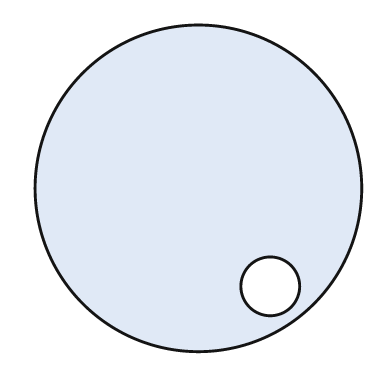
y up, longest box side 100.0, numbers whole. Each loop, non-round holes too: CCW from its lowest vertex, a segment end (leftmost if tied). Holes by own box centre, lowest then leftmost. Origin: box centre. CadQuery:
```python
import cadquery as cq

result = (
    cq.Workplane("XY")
    .moveTo(0.0, 0.0)
    .circle(50.0)
    .moveTo(22.0, -30.0)
    .circle(9.0)
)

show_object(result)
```